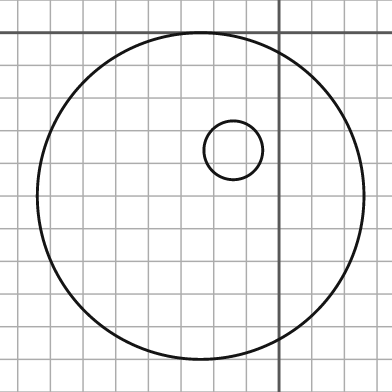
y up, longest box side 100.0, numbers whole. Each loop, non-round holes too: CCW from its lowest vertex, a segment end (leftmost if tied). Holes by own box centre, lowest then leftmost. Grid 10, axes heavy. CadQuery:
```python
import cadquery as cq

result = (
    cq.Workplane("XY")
    .moveTo(-24.0, -50.0)
    .circle(50.0)
    .moveTo(-14.0, -36.0)
    .circle(9.0)
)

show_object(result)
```